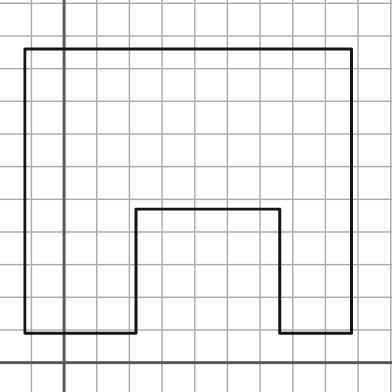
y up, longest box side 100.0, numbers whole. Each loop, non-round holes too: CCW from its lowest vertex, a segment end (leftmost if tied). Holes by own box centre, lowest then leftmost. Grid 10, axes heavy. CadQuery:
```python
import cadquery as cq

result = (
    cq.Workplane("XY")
    .moveTo(-12.0, 9.0)
    .lineTo(22.0, 9.0)
    .lineTo(22.0, 47.0)
    .lineTo(66.0, 47.0)
    .lineTo(66.0, 9.0)
    .lineTo(88.0, 9.0)
    .lineTo(88.0, 96.0)
    .lineTo(-12.0, 96.0)
    .close()
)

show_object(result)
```